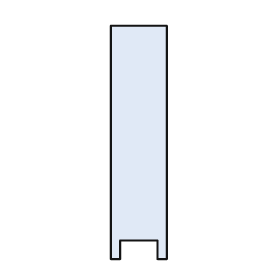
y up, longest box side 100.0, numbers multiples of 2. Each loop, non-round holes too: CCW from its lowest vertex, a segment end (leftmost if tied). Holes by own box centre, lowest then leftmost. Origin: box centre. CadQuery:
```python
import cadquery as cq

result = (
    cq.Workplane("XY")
    .moveTo(-12.0, -50.0)
    .lineTo(-8.0, -50.0)
    .lineTo(-8.0, -42.0)
    .lineTo(8.0, -42.0)
    .lineTo(8.0, -50.0)
    .lineTo(12.0, -50.0)
    .lineTo(12.0, 50.0)
    .lineTo(-12.0, 50.0)
    .close()
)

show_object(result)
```